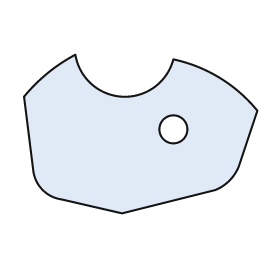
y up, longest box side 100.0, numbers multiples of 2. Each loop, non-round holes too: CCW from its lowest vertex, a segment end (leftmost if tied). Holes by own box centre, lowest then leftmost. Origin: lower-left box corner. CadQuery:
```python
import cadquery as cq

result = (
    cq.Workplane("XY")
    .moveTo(42.0, 0.0)
    .lineTo(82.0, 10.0)
    .threePointArc((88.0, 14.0), (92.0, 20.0))
    .lineTo(100.0, 44.0)
    .threePointArc((84.0, 58.0), (64.0, 66.0))
    .threePointArc((42.0, 50.0), (22.0, 68.0))
    .threePointArc((10.0, 60.0), (0.0, 50.0))
    .lineTo(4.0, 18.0)
    .threePointArc((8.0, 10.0), (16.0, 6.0))
    .close()
    .moveTo(64.0, 36.0)
    .circle(6.0)
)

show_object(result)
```